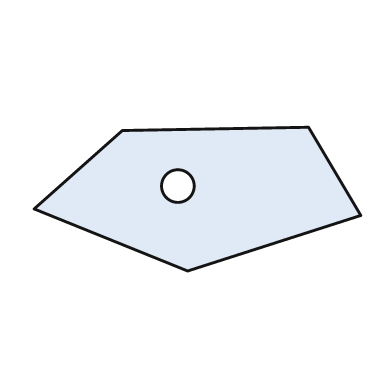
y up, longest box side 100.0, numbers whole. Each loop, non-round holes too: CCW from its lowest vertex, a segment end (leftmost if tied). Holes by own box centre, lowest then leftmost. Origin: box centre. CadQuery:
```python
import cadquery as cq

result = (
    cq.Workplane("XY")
    .moveTo(-3.0, -22.0)
    .lineTo(50.0, -5.0)
    .lineTo(34.0, 22.0)
    .lineTo(-23.0, 21.0)
    .lineTo(-50.0, -3.0)
    .close()
    .moveTo(-6.0, 4.0)
    .circle(5.0)
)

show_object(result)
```